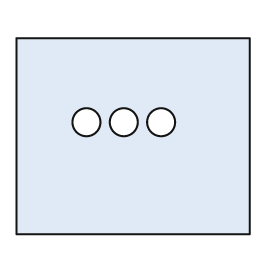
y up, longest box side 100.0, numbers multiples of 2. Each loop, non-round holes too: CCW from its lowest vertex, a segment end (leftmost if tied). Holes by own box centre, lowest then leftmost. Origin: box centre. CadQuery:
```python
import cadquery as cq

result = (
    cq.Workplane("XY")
    .moveTo(-50.0, -42.0)
    .lineTo(50.0, -42.0)
    .lineTo(50.0, 42.0)
    .lineTo(-50.0, 42.0)
    .close()
    .moveTo(-20.0, 6.0)
    .circle(6.0)
    .moveTo(-4.0, 6.0)
    .circle(6.0)
    .moveTo(12.0, 6.0)
    .circle(6.0)
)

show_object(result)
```